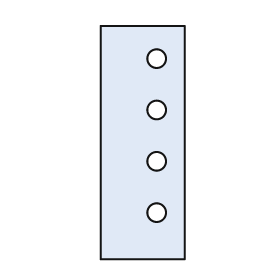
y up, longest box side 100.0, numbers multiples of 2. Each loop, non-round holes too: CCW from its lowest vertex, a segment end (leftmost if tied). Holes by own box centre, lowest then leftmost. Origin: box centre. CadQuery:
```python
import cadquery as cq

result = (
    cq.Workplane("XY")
    .moveTo(-18.0, -50.0)
    .lineTo(18.0, -50.0)
    .lineTo(18.0, 50.0)
    .lineTo(-18.0, 50.0)
    .close()
    .moveTo(6.0, -30.0)
    .circle(4.0)
    .moveTo(6.0, -8.0)
    .circle(4.0)
    .moveTo(6.0, 14.0)
    .circle(4.0)
    .moveTo(6.0, 36.0)
    .circle(4.0)
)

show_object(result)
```